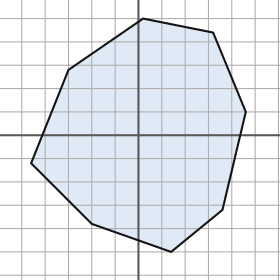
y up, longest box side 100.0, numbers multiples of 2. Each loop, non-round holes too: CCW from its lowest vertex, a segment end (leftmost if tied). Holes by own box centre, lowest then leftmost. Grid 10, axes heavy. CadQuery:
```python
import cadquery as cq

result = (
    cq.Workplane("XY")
    .moveTo(14.0, -50.0)
    .lineTo(36.0, -32.0)
    .lineTo(46.0, 10.0)
    .lineTo(32.0, 44.0)
    .lineTo(2.0, 50.0)
    .lineTo(-30.0, 28.0)
    .lineTo(-46.0, -12.0)
    .lineTo(-20.0, -38.0)
    .close()
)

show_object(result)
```